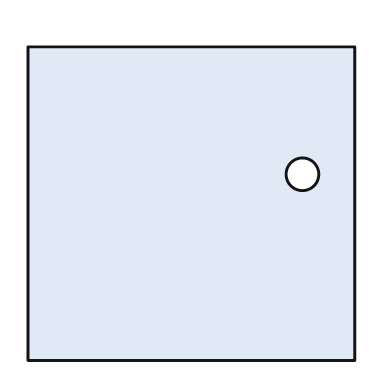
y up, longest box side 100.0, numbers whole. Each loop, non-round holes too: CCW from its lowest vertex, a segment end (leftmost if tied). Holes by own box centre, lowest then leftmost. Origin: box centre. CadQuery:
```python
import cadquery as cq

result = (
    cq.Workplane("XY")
    .moveTo(-50.0, -48.0)
    .lineTo(50.0, -48.0)
    .lineTo(50.0, 48.0)
    .lineTo(-50.0, 48.0)
    .close()
    .moveTo(34.0, 9.0)
    .circle(5.0)
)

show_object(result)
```